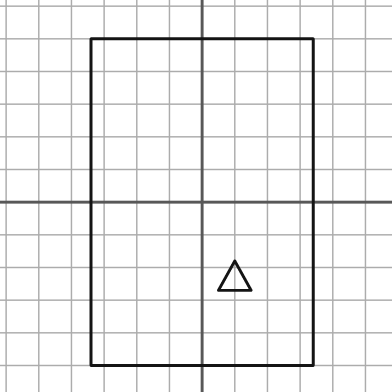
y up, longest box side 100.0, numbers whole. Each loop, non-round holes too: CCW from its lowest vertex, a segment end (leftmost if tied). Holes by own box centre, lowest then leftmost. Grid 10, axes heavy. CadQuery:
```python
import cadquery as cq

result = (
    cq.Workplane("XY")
    .moveTo(-34.0, -50.0)
    .lineTo(34.0, -50.0)
    .lineTo(34.0, 50.0)
    .lineTo(-34.0, 50.0)
    .close()
    .moveTo(5.0, -27.0)
    .lineTo(15.0, -27.0)
    .lineTo(10.0, -18.0)
    .close()
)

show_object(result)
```